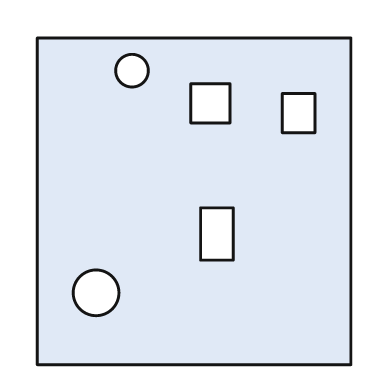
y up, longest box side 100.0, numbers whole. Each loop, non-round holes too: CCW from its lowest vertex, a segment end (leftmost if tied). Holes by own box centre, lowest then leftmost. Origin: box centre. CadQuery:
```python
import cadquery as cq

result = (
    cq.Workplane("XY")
    .moveTo(-48.0, -50.0)
    .lineTo(48.0, -50.0)
    .lineTo(48.0, 50.0)
    .lineTo(-48.0, 50.0)
    .close()
    .moveTo(-30.0, -28.0)
    .circle(7.0)
    .moveTo(2.0, -18.0)
    .lineTo(12.0, -18.0)
    .lineTo(12.0, -2.0)
    .lineTo(2.0, -2.0)
    .close()
    .moveTo(27.0, 21.0)
    .lineTo(37.0, 21.0)
    .lineTo(37.0, 33.0)
    .lineTo(27.0, 33.0)
    .close()
    .moveTo(-1.0, 24.0)
    .lineTo(11.0, 24.0)
    .lineTo(11.0, 36.0)
    .lineTo(-1.0, 36.0)
    .close()
    .moveTo(-19.0, 40.0)
    .circle(5.0)
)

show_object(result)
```